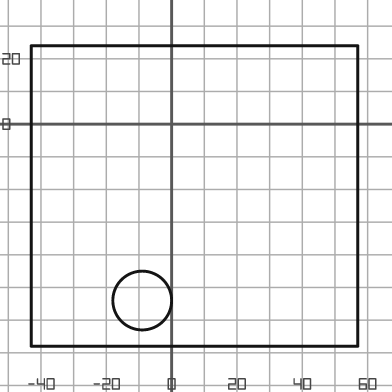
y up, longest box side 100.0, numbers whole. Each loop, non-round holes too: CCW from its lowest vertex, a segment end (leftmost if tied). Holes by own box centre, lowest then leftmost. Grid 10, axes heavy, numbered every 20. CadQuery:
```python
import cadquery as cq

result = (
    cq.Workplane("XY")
    .moveTo(-43.0, -68.0)
    .lineTo(57.0, -68.0)
    .lineTo(57.0, 24.0)
    .lineTo(-43.0, 24.0)
    .close()
    .moveTo(-9.0, -54.0)
    .circle(9.0)
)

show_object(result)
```